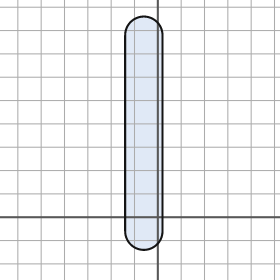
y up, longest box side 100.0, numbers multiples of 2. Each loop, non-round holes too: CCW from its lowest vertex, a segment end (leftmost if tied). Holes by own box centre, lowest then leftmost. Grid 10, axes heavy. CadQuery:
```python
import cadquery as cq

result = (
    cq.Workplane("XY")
    .moveTo(-14.0, -6.0)
    .threePointArc((-6.0, -14.0), (2.0, -6.0))
    .lineTo(2.0, 78.0)
    .threePointArc((-6.0, 86.0), (-14.0, 78.0))
    .close()
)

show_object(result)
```